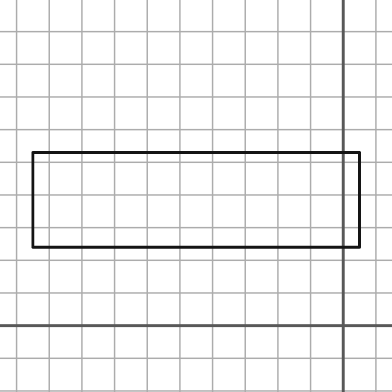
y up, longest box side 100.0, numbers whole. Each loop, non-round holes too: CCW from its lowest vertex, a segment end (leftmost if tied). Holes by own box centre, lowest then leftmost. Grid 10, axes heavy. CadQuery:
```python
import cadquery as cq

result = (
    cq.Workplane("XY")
    .moveTo(-95.0, 24.0)
    .lineTo(5.0, 24.0)
    .lineTo(5.0, 53.0)
    .lineTo(-95.0, 53.0)
    .close()
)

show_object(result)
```